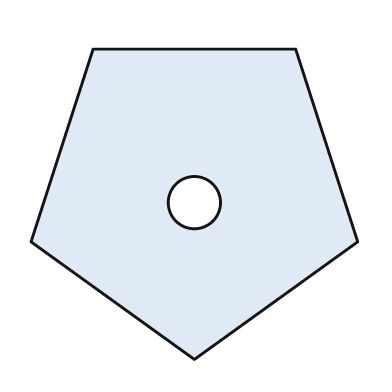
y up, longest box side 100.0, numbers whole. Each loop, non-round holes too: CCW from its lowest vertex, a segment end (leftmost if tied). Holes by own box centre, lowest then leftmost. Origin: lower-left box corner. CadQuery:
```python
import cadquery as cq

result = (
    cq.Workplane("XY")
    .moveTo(50.0, 0.0)
    .lineTo(100.0, 36.0)
    .lineTo(81.0, 95.0)
    .lineTo(19.0, 95.0)
    .lineTo(0.0, 36.0)
    .close()
    .moveTo(50.0, 48.0)
    .circle(8.0)
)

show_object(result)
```